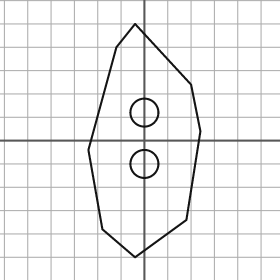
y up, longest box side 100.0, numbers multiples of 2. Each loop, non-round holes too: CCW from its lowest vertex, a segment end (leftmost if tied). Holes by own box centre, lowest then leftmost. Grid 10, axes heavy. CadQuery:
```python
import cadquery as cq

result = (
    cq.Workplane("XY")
    .moveTo(-4.0, -50.0)
    .lineTo(18.0, -34.0)
    .lineTo(24.0, 4.0)
    .lineTo(20.0, 24.0)
    .lineTo(-4.0, 50.0)
    .lineTo(-12.0, 40.0)
    .lineTo(-24.0, -4.0)
    .lineTo(-18.0, -38.0)
    .close()
    .moveTo(0.0, -10.0)
    .circle(6.0)
    .moveTo(0.0, 12.0)
    .circle(6.0)
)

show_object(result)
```